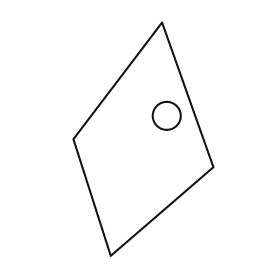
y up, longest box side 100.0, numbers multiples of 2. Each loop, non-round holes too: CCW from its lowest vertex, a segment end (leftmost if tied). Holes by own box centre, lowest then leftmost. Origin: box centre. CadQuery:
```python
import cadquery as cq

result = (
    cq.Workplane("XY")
    .moveTo(-14.0, -50.0)
    .lineTo(30.0, -12.0)
    .lineTo(8.0, 50.0)
    .lineTo(-30.0, 0.0)
    .close()
    .moveTo(10.0, 10.0)
    .circle(6.0)
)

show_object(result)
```